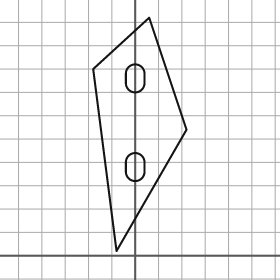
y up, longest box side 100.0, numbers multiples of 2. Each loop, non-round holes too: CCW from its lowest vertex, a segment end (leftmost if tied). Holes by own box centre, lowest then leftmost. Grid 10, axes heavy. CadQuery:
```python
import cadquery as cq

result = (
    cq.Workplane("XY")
    .moveTo(-8.0, 2.0)
    .lineTo(22.0, 54.0)
    .lineTo(6.0, 102.0)
    .lineTo(-18.0, 80.0)
    .close()
    .moveTo(-4.0, 36.0)
    .threePointArc((0.0, 32.0), (4.0, 36.0))
    .lineTo(4.0, 40.0)
    .threePointArc((0.0, 44.0), (-4.0, 40.0))
    .close()
    .moveTo(-4.0, 74.0)
    .threePointArc((0.0, 70.0), (4.0, 74.0))
    .lineTo(4.0, 78.0)
    .threePointArc((0.0, 82.0), (-4.0, 78.0))
    .close()
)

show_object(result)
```